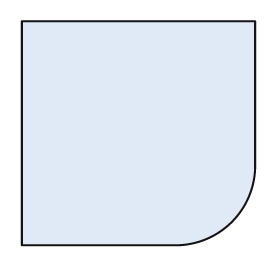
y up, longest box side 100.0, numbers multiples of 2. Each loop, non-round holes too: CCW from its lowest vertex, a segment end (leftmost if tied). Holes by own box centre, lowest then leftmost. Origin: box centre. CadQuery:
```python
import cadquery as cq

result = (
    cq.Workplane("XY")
    .moveTo(-50.0, -48.0)
    .lineTo(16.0, -48.0)
    .threePointArc((40.0, -38.0), (50.0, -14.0))
    .lineTo(50.0, 48.0)
    .lineTo(-50.0, 48.0)
    .close()
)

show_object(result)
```